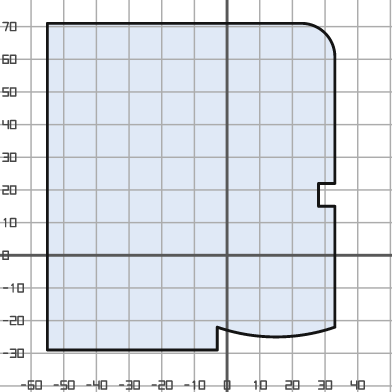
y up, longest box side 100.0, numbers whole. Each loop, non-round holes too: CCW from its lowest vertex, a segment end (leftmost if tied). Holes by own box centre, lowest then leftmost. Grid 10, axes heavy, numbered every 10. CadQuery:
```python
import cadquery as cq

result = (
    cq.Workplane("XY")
    .moveTo(-55.0, -29.0)
    .lineTo(-3.0, -29.0)
    .lineTo(-3.0, -22.0)
    .threePointArc((15.0, -25.0), (33.0, -22.0))
    .lineTo(33.0, 15.0)
    .lineTo(28.0, 15.0)
    .lineTo(28.0, 22.0)
    .lineTo(33.0, 22.0)
    .lineTo(33.0, 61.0)
    .threePointArc((30.0, 68.0), (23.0, 71.0))
    .lineTo(-55.0, 71.0)
    .close()
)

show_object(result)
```